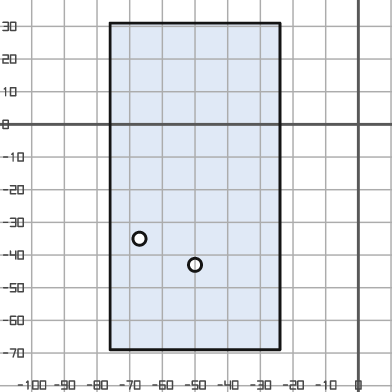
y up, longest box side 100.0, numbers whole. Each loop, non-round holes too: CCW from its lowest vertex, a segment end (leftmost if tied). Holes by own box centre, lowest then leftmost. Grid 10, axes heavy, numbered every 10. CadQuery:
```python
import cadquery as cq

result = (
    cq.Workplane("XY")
    .moveTo(-76.0, -69.0)
    .lineTo(-24.0, -69.0)
    .lineTo(-24.0, 31.0)
    .lineTo(-76.0, 31.0)
    .close()
    .moveTo(-50.0, -43.0)
    .circle(2.0)
    .moveTo(-67.0, -35.0)
    .circle(2.0)
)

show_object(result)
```